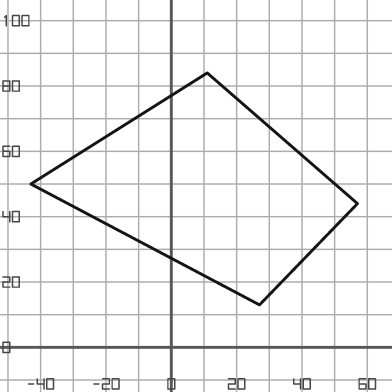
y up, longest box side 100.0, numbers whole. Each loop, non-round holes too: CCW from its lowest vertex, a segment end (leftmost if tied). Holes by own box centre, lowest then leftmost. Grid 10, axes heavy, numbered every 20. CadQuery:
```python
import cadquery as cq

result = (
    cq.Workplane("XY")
    .moveTo(27.0, 13.0)
    .lineTo(57.0, 44.0)
    .lineTo(11.0, 84.0)
    .lineTo(-43.0, 50.0)
    .close()
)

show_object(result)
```